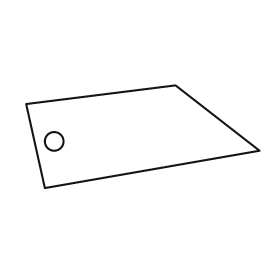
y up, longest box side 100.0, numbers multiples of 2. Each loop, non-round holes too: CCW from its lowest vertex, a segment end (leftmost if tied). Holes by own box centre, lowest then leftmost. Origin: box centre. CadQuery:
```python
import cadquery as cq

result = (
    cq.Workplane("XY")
    .moveTo(-42.0, -22.0)
    .lineTo(50.0, -6.0)
    .lineTo(14.0, 22.0)
    .lineTo(-50.0, 14.0)
    .close()
    .moveTo(-38.0, -2.0)
    .circle(4.0)
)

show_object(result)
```